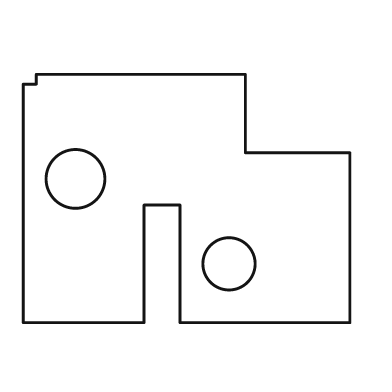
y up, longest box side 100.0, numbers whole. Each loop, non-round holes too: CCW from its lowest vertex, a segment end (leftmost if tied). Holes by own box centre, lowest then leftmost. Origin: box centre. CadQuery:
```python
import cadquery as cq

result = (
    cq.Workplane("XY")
    .moveTo(-50.0, -38.0)
    .lineTo(-13.0, -38.0)
    .lineTo(-13.0, -2.0)
    .lineTo(-2.0, -2.0)
    .lineTo(-2.0, -38.0)
    .lineTo(50.0, -38.0)
    .lineTo(50.0, 14.0)
    .lineTo(18.0, 14.0)
    .lineTo(18.0, 38.0)
    .lineTo(-46.0, 38.0)
    .lineTo(-46.0, 35.0)
    .lineTo(-50.0, 35.0)
    .close()
    .moveTo(13.0, -20.0)
    .circle(8.0)
    .moveTo(-34.0, 6.0)
    .circle(9.0)
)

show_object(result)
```